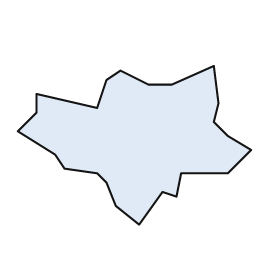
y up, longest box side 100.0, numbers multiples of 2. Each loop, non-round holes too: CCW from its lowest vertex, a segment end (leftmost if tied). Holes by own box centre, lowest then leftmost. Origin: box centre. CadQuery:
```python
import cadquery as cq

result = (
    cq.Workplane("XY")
    .moveTo(2.0, -34.0)
    .lineTo(12.0, -20.0)
    .lineTo(18.0, -22.0)
    .lineTo(20.0, -12.0)
    .lineTo(40.0, -12.0)
    .lineTo(50.0, -2.0)
    .lineTo(40.0, 4.0)
    .lineTo(34.0, 10.0)
    .lineTo(36.0, 18.0)
    .lineTo(34.0, 34.0)
    .lineTo(16.0, 26.0)
    .lineTo(6.0, 26.0)
    .lineTo(-6.0, 32.0)
    .lineTo(-12.0, 28.0)
    .lineTo(-16.0, 16.0)
    .lineTo(-42.0, 22.0)
    .lineTo(-42.0, 14.0)
    .lineTo(-50.0, 6.0)
    .lineTo(-34.0, -4.0)
    .lineTo(-30.0, -10.0)
    .lineTo(-16.0, -12.0)
    .lineTo(-12.0, -16.0)
    .lineTo(-8.0, -26.0)
    .close()
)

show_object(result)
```